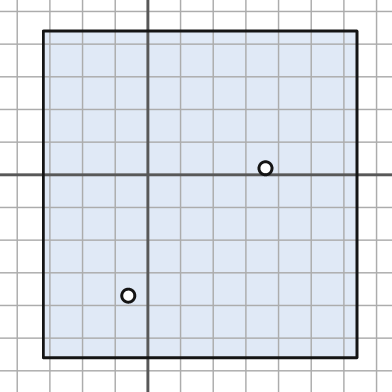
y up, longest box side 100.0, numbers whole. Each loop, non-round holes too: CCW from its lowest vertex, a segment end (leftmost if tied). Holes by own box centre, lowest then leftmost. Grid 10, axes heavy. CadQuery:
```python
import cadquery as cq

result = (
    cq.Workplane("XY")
    .moveTo(-32.0, -56.0)
    .lineTo(64.0, -56.0)
    .lineTo(64.0, 44.0)
    .lineTo(-32.0, 44.0)
    .close()
    .moveTo(-6.0, -37.0)
    .circle(2.0)
    .moveTo(36.0, 2.0)
    .circle(2.0)
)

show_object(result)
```